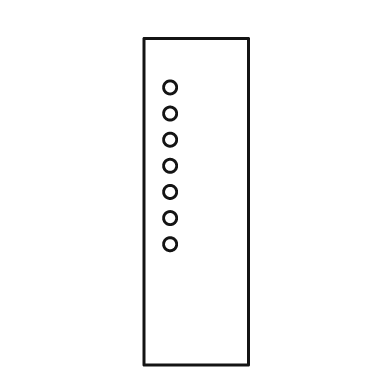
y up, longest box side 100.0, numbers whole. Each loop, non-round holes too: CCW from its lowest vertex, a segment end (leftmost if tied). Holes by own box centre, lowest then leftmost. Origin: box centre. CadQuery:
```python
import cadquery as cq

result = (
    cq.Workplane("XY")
    .moveTo(-16.0, -50.0)
    .lineTo(16.0, -50.0)
    .lineTo(16.0, 50.0)
    .lineTo(-16.0, 50.0)
    .close()
    .moveTo(-8.0, -13.0)
    .circle(2.0)
    .moveTo(-8.0, -5.0)
    .circle(2.0)
    .moveTo(-8.0, 3.0)
    .circle(2.0)
    .moveTo(-8.0, 11.0)
    .circle(2.0)
    .moveTo(-8.0, 19.0)
    .circle(2.0)
    .moveTo(-8.0, 27.0)
    .circle(2.0)
    .moveTo(-8.0, 35.0)
    .circle(2.0)
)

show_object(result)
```